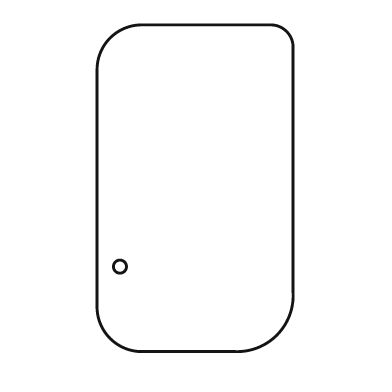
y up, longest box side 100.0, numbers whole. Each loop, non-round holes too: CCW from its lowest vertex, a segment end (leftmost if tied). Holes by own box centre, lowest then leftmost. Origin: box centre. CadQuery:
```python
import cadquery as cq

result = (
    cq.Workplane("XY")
    .moveTo(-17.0, -50.0)
    .lineTo(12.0, -50.0)
    .threePointArc((25.0, -45.0), (30.0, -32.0))
    .lineTo(30.0, 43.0)
    .threePointArc((28.0, 48.0), (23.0, 50.0))
    .lineTo(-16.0, 50.0)
    .threePointArc((-26.0, 46.0), (-30.0, 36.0))
    .lineTo(-30.0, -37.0)
    .threePointArc((-26.0, -46.0), (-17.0, -50.0))
    .close()
    .moveTo(-23.0, -24.0)
    .circle(2.0)
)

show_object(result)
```